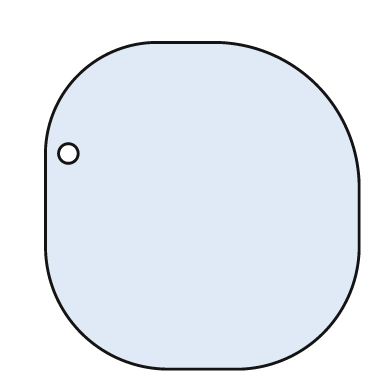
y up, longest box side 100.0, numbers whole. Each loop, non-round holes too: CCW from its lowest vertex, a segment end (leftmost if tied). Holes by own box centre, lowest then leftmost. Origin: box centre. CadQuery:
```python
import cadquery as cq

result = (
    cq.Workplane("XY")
    .moveTo(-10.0, -50.0)
    .lineTo(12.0, -50.0)
    .threePointArc((37.0, -39.0), (48.0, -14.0))
    .lineTo(48.0, 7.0)
    .threePointArc((35.0, 37.0), (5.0, 50.0))
    .lineTo(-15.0, 50.0)
    .threePointArc((-38.0, 40.0), (-48.0, 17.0))
    .lineTo(-48.0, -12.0)
    .threePointArc((-37.0, -39.0), (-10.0, -50.0))
    .close()
    .moveTo(-41.0, 16.0)
    .circle(3.0)
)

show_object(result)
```